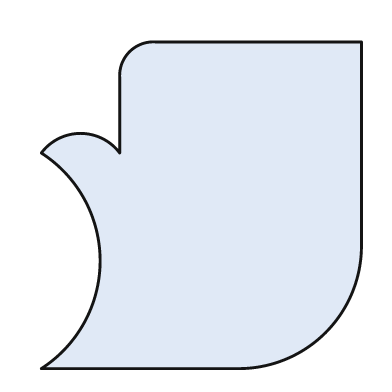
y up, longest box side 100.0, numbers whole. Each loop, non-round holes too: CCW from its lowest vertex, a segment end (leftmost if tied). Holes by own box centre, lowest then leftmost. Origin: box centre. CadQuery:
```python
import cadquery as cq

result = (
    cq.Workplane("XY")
    .moveTo(-49.0, -50.0)
    .lineTo(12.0, -50.0)
    .threePointArc((38.0, -39.0), (49.0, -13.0))
    .lineTo(49.0, 50.0)
    .lineTo(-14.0, 50.0)
    .threePointArc((-22.0, 47.0), (-25.0, 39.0))
    .lineTo(-25.0, 16.0)
    .threePointArc((-37.0, 22.0), (-49.0, 16.0))
    .threePointArc((-31.0, -17.0), (-49.0, -50.0))
    .close()
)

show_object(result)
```